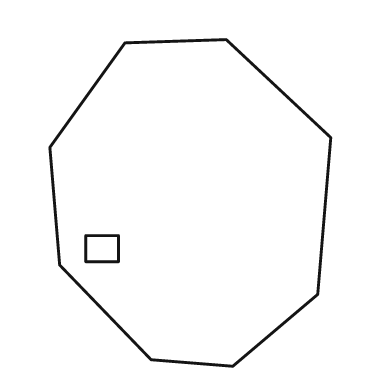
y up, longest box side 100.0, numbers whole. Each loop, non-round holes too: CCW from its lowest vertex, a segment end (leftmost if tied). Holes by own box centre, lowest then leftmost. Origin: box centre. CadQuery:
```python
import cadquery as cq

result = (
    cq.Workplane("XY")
    .moveTo(13.0, -50.0)
    .lineTo(39.0, -28.0)
    .lineTo(43.0, 20.0)
    .lineTo(11.0, 50.0)
    .lineTo(-20.0, 49.0)
    .lineTo(-43.0, 17.0)
    .lineTo(-40.0, -19.0)
    .lineTo(-12.0, -48.0)
    .close()
    .moveTo(-32.0, -18.0)
    .lineTo(-22.0, -18.0)
    .lineTo(-22.0, -10.0)
    .lineTo(-32.0, -10.0)
    .close()
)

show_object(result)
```